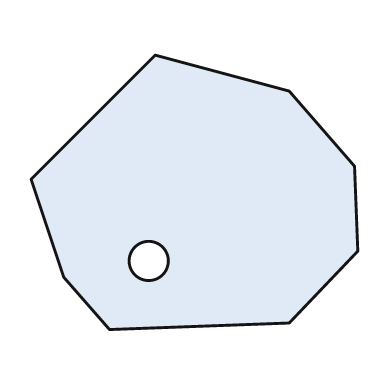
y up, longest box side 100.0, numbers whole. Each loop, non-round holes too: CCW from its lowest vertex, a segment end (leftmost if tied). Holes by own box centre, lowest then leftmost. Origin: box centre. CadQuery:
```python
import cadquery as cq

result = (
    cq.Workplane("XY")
    .moveTo(-26.0, -42.0)
    .lineTo(29.0, -40.0)
    .lineTo(50.0, -18.0)
    .lineTo(49.0, 8.0)
    .lineTo(29.0, 31.0)
    .lineTo(-12.0, 42.0)
    .lineTo(-50.0, 4.0)
    .lineTo(-40.0, -26.0)
    .close()
    .moveTo(-14.0, -21.0)
    .circle(6.0)
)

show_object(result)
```